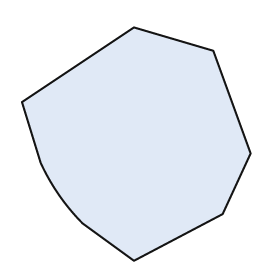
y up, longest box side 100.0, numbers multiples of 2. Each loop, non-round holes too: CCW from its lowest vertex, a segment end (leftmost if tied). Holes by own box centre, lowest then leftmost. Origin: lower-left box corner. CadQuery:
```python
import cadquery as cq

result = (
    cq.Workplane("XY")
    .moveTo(48.0, 0.0)
    .lineTo(86.0, 20.0)
    .lineTo(98.0, 46.0)
    .lineTo(82.0, 90.0)
    .lineTo(48.0, 100.0)
    .lineTo(0.0, 68.0)
    .lineTo(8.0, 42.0)
    .threePointArc((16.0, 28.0), (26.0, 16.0))
    .close()
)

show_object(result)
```